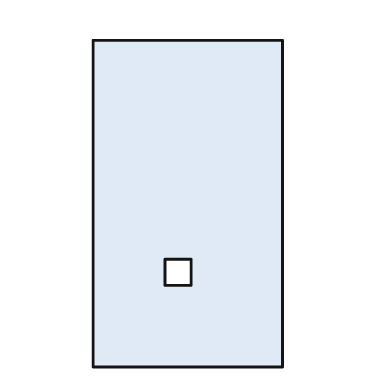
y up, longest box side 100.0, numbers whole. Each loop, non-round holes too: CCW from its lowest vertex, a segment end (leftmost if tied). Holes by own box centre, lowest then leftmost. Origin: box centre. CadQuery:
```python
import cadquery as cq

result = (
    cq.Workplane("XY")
    .moveTo(-29.0, -50.0)
    .lineTo(29.0, -50.0)
    .lineTo(29.0, 50.0)
    .lineTo(-29.0, 50.0)
    .close()
    .moveTo(-7.0, -25.0)
    .lineTo(1.0, -25.0)
    .lineTo(1.0, -17.0)
    .lineTo(-7.0, -17.0)
    .close()
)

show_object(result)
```